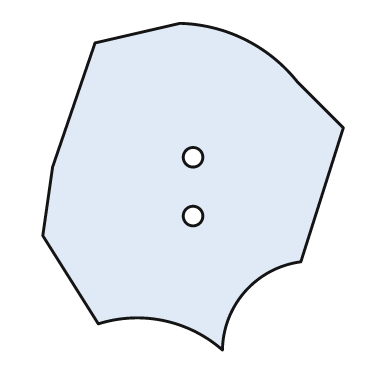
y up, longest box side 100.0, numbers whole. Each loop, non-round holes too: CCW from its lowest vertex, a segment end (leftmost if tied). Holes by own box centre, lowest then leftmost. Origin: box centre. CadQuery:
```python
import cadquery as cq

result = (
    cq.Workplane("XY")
    .moveTo(9.0, -50.0)
    .threePointArc((16.0, -32.0), (33.0, -23.0))
    .lineTo(46.0, 18.0)
    .lineTo(32.0, 32.0)
    .threePointArc((16.0, 45.0), (-4.0, 50.0))
    .lineTo(-30.0, 44.0)
    .lineTo(-43.0, 6.0)
    .lineTo(-46.0, -15.0)
    .lineTo(-29.0, -42.0)
    .threePointArc((-9.0, -41.0), (9.0, -50.0))
    .close()
    .moveTo(0.0, -9.0)
    .circle(3.0)
    .moveTo(0.0, 9.0)
    .circle(3.0)
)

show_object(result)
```